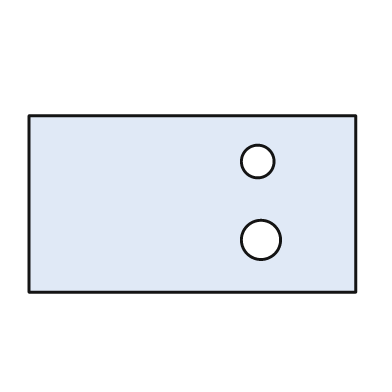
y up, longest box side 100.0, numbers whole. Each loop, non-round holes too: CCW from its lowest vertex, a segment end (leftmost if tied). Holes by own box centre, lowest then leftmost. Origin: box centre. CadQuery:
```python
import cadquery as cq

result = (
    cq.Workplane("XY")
    .moveTo(-50.0, -27.0)
    .lineTo(50.0, -27.0)
    .lineTo(50.0, 27.0)
    .lineTo(-50.0, 27.0)
    .close()
    .moveTo(21.0, -11.0)
    .circle(6.0)
    .moveTo(20.0, 13.0)
    .circle(5.0)
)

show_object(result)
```